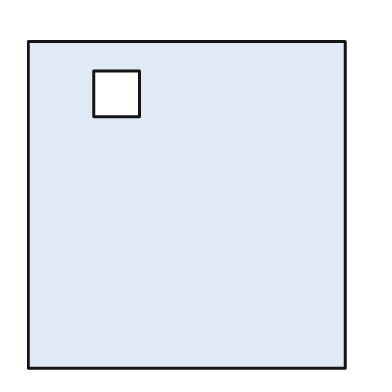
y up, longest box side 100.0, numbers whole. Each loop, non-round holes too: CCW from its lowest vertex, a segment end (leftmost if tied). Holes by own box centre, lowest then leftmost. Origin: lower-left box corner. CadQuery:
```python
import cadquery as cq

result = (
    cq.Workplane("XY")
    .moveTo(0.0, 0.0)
    .lineTo(97.0, 0.0)
    .lineTo(97.0, 100.0)
    .lineTo(0.0, 100.0)
    .close()
    .moveTo(20.0, 77.0)
    .lineTo(34.0, 77.0)
    .lineTo(34.0, 91.0)
    .lineTo(20.0, 91.0)
    .close()
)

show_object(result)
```